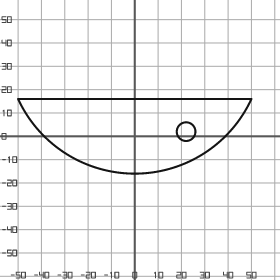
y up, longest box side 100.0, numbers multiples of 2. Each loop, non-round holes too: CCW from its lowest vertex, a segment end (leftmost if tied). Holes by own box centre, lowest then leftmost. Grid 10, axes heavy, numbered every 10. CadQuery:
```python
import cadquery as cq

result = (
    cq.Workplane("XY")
    .moveTo(-50.0, 16.0)
    .threePointArc((0.0, -16.0), (50.0, 16.0))
    .close()
    .moveTo(22.0, 2.0)
    .circle(4.0)
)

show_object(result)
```